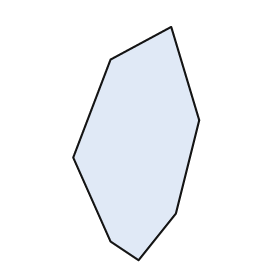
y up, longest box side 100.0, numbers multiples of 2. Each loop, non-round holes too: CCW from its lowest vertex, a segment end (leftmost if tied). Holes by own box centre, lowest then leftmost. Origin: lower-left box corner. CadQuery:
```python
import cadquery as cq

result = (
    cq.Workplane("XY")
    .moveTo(28.0, 0.0)
    .lineTo(44.0, 20.0)
    .lineTo(54.0, 60.0)
    .lineTo(42.0, 100.0)
    .lineTo(16.0, 86.0)
    .lineTo(0.0, 44.0)
    .lineTo(16.0, 8.0)
    .close()
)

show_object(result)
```